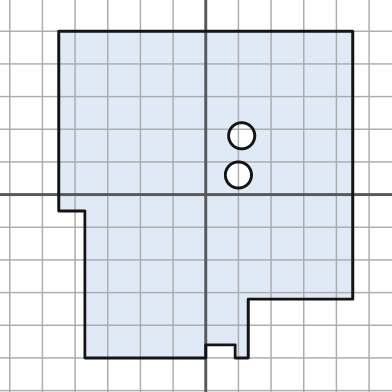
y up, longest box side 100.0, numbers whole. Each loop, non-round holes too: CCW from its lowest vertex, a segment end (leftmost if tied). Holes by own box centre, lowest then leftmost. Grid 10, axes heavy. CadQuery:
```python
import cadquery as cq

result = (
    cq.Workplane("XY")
    .moveTo(-37.0, -50.0)
    .lineTo(0.0, -50.0)
    .lineTo(0.0, -46.0)
    .lineTo(9.0, -46.0)
    .lineTo(9.0, -50.0)
    .lineTo(13.0, -50.0)
    .lineTo(13.0, -32.0)
    .lineTo(45.0, -32.0)
    .lineTo(45.0, 50.0)
    .lineTo(-45.0, 50.0)
    .lineTo(-45.0, -5.0)
    .lineTo(-37.0, -5.0)
    .close()
    .moveTo(10.0, 6.0)
    .circle(4.0)
    .moveTo(11.0, 18.0)
    .circle(4.0)
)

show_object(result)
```